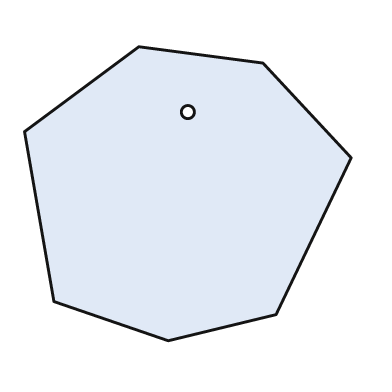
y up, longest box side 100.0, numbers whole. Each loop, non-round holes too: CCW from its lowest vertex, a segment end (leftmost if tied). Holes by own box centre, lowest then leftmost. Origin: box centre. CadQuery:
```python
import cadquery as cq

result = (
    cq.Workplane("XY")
    .moveTo(-6.0, -45.0)
    .lineTo(27.0, -37.0)
    .lineTo(50.0, 11.0)
    .lineTo(23.0, 40.0)
    .lineTo(-15.0, 45.0)
    .lineTo(-50.0, 19.0)
    .lineTo(-41.0, -33.0)
    .close()
    .moveTo(0.0, 25.0)
    .circle(2.0)
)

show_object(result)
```